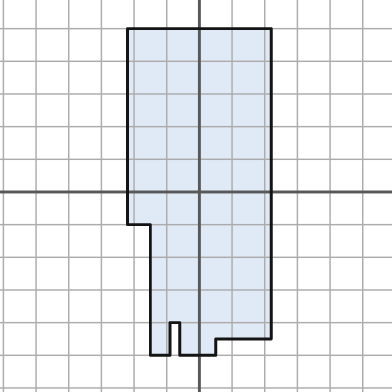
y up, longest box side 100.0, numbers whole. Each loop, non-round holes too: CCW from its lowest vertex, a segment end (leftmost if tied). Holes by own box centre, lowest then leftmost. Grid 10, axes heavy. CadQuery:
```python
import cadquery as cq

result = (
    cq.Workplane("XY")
    .moveTo(-15.0, -50.0)
    .lineTo(-9.0, -50.0)
    .lineTo(-9.0, -40.0)
    .lineTo(-6.0, -40.0)
    .lineTo(-6.0, -50.0)
    .lineTo(5.0, -50.0)
    .lineTo(5.0, -45.0)
    .lineTo(22.0, -45.0)
    .lineTo(22.0, 50.0)
    .lineTo(-22.0, 50.0)
    .lineTo(-22.0, -10.0)
    .lineTo(-15.0, -10.0)
    .close()
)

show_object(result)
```